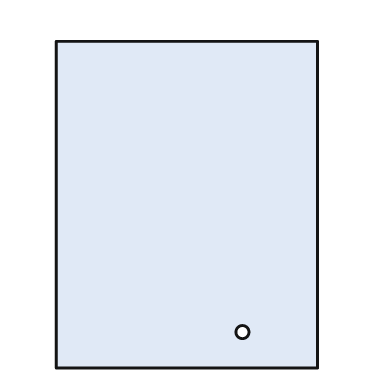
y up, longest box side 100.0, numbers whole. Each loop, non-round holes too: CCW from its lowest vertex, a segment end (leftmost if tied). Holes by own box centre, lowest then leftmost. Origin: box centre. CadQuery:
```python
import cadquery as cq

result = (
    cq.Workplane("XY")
    .moveTo(-40.0, -50.0)
    .lineTo(40.0, -50.0)
    .lineTo(40.0, 50.0)
    .lineTo(-40.0, 50.0)
    .close()
    .moveTo(17.0, -39.0)
    .circle(2.0)
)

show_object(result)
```